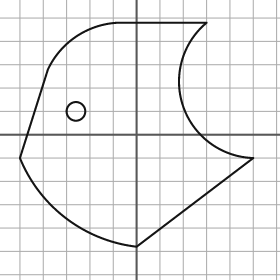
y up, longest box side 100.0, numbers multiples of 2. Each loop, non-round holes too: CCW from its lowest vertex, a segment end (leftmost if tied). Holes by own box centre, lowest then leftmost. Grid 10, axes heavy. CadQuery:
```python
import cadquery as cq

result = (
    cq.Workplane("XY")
    .moveTo(0.0, -48.0)
    .lineTo(50.0, -10.0)
    .threePointArc((20.0, 12.0), (30.0, 48.0))
    .lineTo(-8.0, 48.0)
    .threePointArc((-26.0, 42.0), (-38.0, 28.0))
    .lineTo(-50.0, -10.0)
    .threePointArc((-30.0, -36.0), (0.0, -48.0))
    .close()
    .moveTo(-26.0, 10.0)
    .circle(4.0)
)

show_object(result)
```